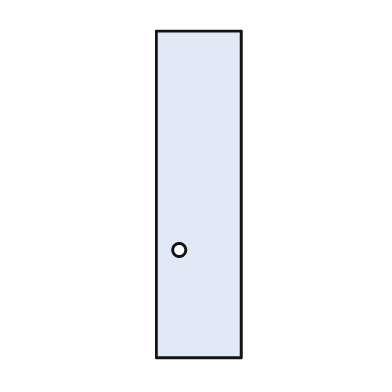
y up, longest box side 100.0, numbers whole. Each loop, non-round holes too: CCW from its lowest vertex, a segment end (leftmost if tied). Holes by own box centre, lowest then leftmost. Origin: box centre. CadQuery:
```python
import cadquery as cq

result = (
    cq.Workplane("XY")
    .moveTo(-13.0, -50.0)
    .lineTo(13.0, -50.0)
    .lineTo(13.0, 50.0)
    .lineTo(-13.0, 50.0)
    .close()
    .moveTo(-6.0, -17.0)
    .circle(2.0)
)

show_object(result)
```